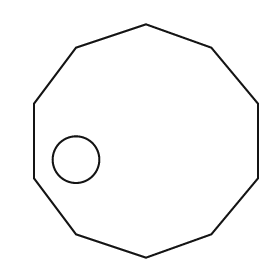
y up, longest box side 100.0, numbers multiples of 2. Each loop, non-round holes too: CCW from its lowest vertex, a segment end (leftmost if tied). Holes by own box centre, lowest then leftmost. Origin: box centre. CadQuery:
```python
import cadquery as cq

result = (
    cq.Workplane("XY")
    .moveTo(0.0, -50.0)
    .lineTo(28.0, -40.0)
    .lineTo(48.0, -16.0)
    .lineTo(48.0, 16.0)
    .lineTo(28.0, 40.0)
    .lineTo(0.0, 50.0)
    .lineTo(-30.0, 40.0)
    .lineTo(-48.0, 16.0)
    .lineTo(-48.0, -16.0)
    .lineTo(-30.0, -40.0)
    .close()
    .moveTo(-30.0, -8.0)
    .circle(10.0)
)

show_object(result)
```